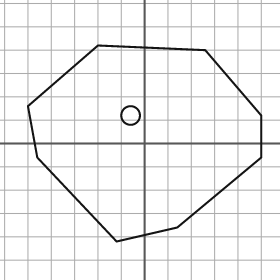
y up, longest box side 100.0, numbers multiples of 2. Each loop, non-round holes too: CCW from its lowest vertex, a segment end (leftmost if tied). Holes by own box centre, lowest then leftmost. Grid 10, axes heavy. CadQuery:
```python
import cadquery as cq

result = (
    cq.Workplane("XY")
    .moveTo(-12.0, -42.0)
    .lineTo(14.0, -36.0)
    .lineTo(50.0, -6.0)
    .lineTo(50.0, 12.0)
    .lineTo(26.0, 40.0)
    .lineTo(-20.0, 42.0)
    .lineTo(-50.0, 16.0)
    .lineTo(-46.0, -6.0)
    .close()
    .moveTo(-6.0, 12.0)
    .circle(4.0)
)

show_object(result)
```